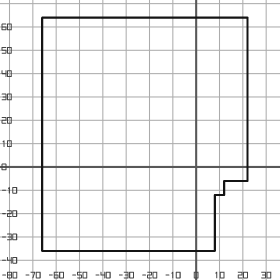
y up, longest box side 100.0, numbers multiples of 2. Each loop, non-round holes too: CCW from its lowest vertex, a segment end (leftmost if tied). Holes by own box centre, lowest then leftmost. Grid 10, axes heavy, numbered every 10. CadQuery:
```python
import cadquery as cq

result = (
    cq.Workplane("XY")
    .moveTo(-66.0, -36.0)
    .lineTo(8.0, -36.0)
    .lineTo(8.0, -12.0)
    .lineTo(12.0, -12.0)
    .lineTo(12.0, -6.0)
    .lineTo(22.0, -6.0)
    .lineTo(22.0, 64.0)
    .lineTo(-66.0, 64.0)
    .close()
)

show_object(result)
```